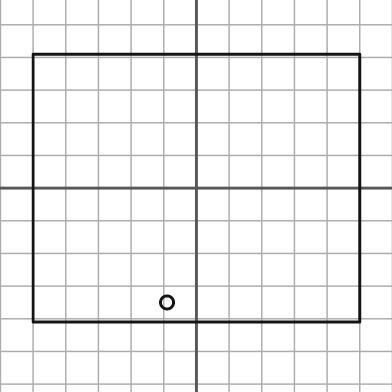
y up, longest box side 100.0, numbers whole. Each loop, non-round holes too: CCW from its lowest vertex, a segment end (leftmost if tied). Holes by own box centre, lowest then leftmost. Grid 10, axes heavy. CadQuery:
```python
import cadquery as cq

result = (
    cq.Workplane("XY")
    .moveTo(-50.0, -41.0)
    .lineTo(50.0, -41.0)
    .lineTo(50.0, 41.0)
    .lineTo(-50.0, 41.0)
    .close()
    .moveTo(-9.0, -35.0)
    .circle(2.0)
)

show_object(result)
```